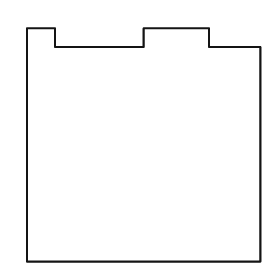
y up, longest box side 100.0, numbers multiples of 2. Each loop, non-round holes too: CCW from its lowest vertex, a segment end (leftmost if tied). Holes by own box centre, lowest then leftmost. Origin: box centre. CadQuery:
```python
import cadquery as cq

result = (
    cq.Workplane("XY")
    .moveTo(-50.0, -50.0)
    .lineTo(50.0, -50.0)
    .lineTo(50.0, 42.0)
    .lineTo(28.0, 42.0)
    .lineTo(28.0, 50.0)
    .lineTo(0.0, 50.0)
    .lineTo(0.0, 42.0)
    .lineTo(-38.0, 42.0)
    .lineTo(-38.0, 50.0)
    .lineTo(-50.0, 50.0)
    .close()
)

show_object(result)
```